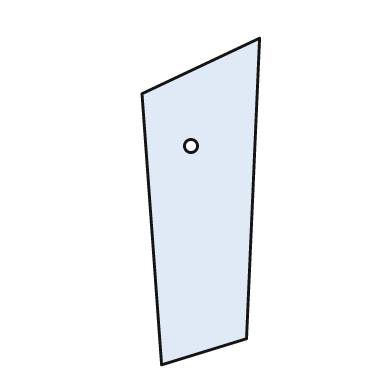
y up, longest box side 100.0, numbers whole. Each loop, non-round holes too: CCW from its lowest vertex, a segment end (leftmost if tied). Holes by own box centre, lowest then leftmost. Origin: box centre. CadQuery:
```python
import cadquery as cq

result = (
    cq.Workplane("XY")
    .moveTo(-12.0, -50.0)
    .lineTo(14.0, -42.0)
    .lineTo(18.0, 50.0)
    .lineTo(-18.0, 33.0)
    .close()
    .moveTo(-3.0, 17.0)
    .circle(2.0)
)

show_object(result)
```